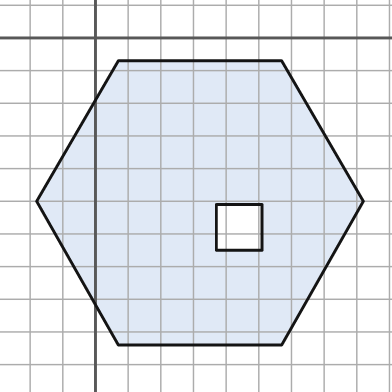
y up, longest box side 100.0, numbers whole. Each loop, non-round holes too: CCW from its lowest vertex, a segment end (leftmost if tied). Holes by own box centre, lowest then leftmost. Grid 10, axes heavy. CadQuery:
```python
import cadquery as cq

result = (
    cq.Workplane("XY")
    .moveTo(7.0, -94.0)
    .lineTo(57.0, -94.0)
    .lineTo(82.0, -50.0)
    .lineTo(57.0, -7.0)
    .lineTo(7.0, -7.0)
    .lineTo(-18.0, -50.0)
    .close()
    .moveTo(37.0, -65.0)
    .lineTo(51.0, -65.0)
    .lineTo(51.0, -51.0)
    .lineTo(37.0, -51.0)
    .close()
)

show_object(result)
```